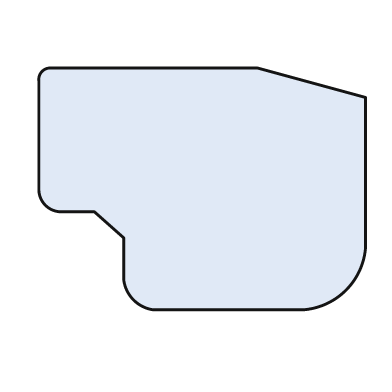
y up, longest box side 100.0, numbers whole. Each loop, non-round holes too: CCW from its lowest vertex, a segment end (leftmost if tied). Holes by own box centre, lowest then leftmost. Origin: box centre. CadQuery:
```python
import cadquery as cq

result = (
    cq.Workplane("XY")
    .moveTo(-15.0, -37.0)
    .lineTo(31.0, -37.0)
    .threePointArc((44.0, -31.0), (50.0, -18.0))
    .lineTo(50.0, 28.0)
    .lineTo(17.0, 37.0)
    .lineTo(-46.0, 37.0)
    .threePointArc((-49.0, 36.0), (-50.0, 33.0))
    .lineTo(-50.0, 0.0)
    .threePointArc((-48.0, -5.0), (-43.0, -7.0))
    .lineTo(-33.0, -7.0)
    .lineTo(-24.0, -15.0)
    .lineTo(-24.0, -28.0)
    .threePointArc((-21.0, -34.0), (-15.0, -37.0))
    .close()
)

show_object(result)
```